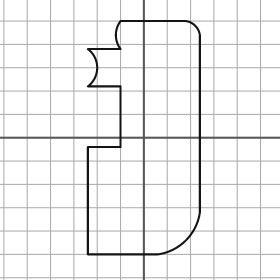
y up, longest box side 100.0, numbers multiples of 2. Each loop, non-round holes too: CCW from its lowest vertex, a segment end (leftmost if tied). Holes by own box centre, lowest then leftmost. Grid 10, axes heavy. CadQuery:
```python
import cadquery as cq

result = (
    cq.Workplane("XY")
    .moveTo(-24.0, -50.0)
    .lineTo(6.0, -50.0)
    .threePointArc((18.0, -44.0), (24.0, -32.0))
    .lineTo(24.0, 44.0)
    .threePointArc((22.0, 48.0), (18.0, 50.0))
    .lineTo(-10.0, 50.0)
    .threePointArc((-12.0, 44.0), (-10.0, 38.0))
    .lineTo(-24.0, 38.0)
    .threePointArc((-20.0, 30.0), (-24.0, 22.0))
    .lineTo(-10.0, 22.0)
    .lineTo(-10.0, -4.0)
    .lineTo(-24.0, -4.0)
    .close()
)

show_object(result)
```